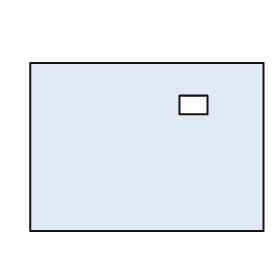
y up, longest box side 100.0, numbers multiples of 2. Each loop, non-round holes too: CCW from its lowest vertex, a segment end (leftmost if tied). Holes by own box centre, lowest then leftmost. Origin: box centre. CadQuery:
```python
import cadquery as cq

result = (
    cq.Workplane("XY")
    .moveTo(-50.0, -36.0)
    .lineTo(50.0, -36.0)
    .lineTo(50.0, 36.0)
    .lineTo(-50.0, 36.0)
    .close()
    .moveTo(14.0, 14.0)
    .lineTo(26.0, 14.0)
    .lineTo(26.0, 22.0)
    .lineTo(14.0, 22.0)
    .close()
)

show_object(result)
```